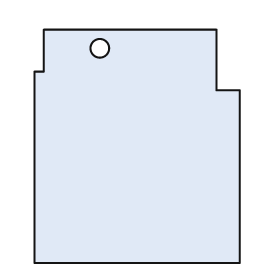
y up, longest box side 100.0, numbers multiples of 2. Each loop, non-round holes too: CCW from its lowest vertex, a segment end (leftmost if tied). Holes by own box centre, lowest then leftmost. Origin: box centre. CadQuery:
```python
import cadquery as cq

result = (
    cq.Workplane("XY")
    .moveTo(-44.0, -50.0)
    .lineTo(44.0, -50.0)
    .lineTo(44.0, 24.0)
    .lineTo(34.0, 24.0)
    .lineTo(34.0, 50.0)
    .lineTo(-40.0, 50.0)
    .lineTo(-40.0, 32.0)
    .lineTo(-44.0, 32.0)
    .close()
    .moveTo(-16.0, 42.0)
    .circle(4.0)
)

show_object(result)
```